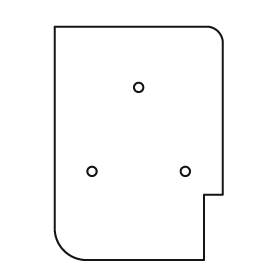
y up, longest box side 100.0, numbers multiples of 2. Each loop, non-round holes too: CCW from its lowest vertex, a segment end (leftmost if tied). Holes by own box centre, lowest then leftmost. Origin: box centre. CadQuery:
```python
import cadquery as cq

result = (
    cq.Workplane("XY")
    .moveTo(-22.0, -50.0)
    .lineTo(28.0, -50.0)
    .lineTo(28.0, -22.0)
    .lineTo(36.0, -22.0)
    .lineTo(36.0, 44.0)
    .threePointArc((34.0, 48.0), (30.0, 50.0))
    .lineTo(-36.0, 50.0)
    .lineTo(-36.0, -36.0)
    .threePointArc((-32.0, -46.0), (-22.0, -50.0))
    .close()
    .moveTo(-20.0, -12.0)
    .circle(2.0)
    .moveTo(20.0, -12.0)
    .circle(2.0)
    .moveTo(0.0, 24.0)
    .circle(2.0)
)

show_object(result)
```